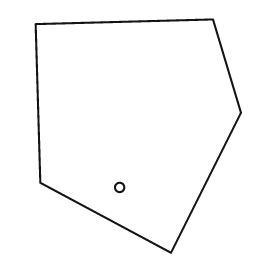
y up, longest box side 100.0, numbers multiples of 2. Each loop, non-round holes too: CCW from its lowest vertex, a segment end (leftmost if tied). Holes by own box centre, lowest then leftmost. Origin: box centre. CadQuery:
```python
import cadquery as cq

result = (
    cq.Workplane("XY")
    .moveTo(14.0, -50.0)
    .lineTo(44.0, 10.0)
    .lineTo(32.0, 50.0)
    .lineTo(-44.0, 48.0)
    .lineTo(-42.0, -20.0)
    .close()
    .moveTo(-8.0, -22.0)
    .circle(2.0)
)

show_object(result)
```